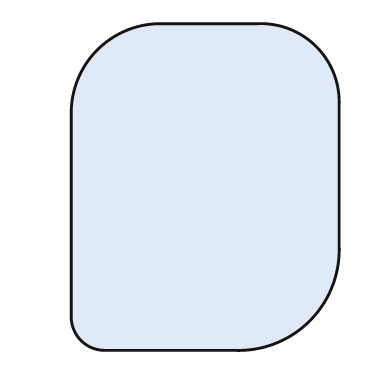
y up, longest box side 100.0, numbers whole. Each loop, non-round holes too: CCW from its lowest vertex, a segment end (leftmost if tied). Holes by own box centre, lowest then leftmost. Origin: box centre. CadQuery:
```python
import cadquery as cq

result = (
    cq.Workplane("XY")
    .moveTo(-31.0, -50.0)
    .lineTo(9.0, -50.0)
    .threePointArc((32.0, -41.0), (41.0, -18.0))
    .lineTo(41.0, 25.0)
    .threePointArc((34.0, 43.0), (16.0, 50.0))
    .lineTo(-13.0, 50.0)
    .threePointArc((-33.0, 42.0), (-41.0, 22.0))
    .lineTo(-41.0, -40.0)
    .threePointArc((-38.0, -47.0), (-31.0, -50.0))
    .close()
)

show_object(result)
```